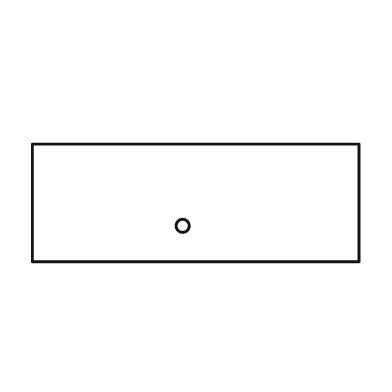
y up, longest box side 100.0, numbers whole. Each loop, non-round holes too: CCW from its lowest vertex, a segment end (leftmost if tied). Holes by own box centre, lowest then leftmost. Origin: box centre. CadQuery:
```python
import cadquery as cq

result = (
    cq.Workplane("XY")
    .moveTo(-50.0, -18.0)
    .lineTo(50.0, -18.0)
    .lineTo(50.0, 18.0)
    .lineTo(-50.0, 18.0)
    .close()
    .moveTo(-4.0, -7.0)
    .circle(2.0)
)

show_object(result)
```